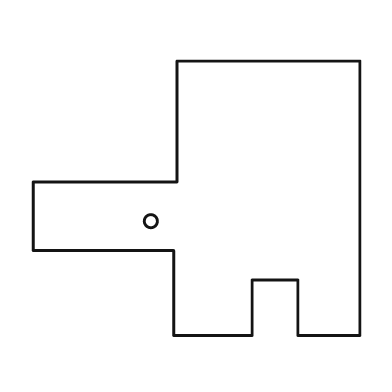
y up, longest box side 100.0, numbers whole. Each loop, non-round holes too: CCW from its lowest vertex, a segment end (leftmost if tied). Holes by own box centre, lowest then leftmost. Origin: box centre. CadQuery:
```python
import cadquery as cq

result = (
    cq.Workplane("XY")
    .moveTo(-7.0, -42.0)
    .lineTo(17.0, -42.0)
    .lineTo(17.0, -25.0)
    .lineTo(31.0, -25.0)
    .lineTo(31.0, -42.0)
    .lineTo(50.0, -42.0)
    .lineTo(50.0, 42.0)
    .lineTo(-6.0, 42.0)
    .lineTo(-6.0, 5.0)
    .lineTo(-50.0, 5.0)
    .lineTo(-50.0, -16.0)
    .lineTo(-7.0, -16.0)
    .close()
    .moveTo(-14.0, -7.0)
    .circle(2.0)
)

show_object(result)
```